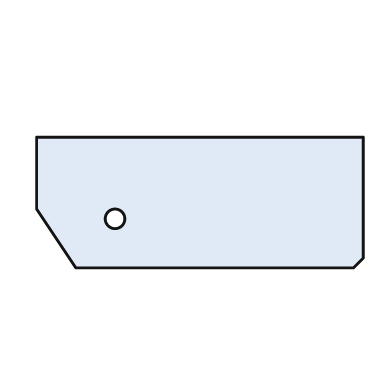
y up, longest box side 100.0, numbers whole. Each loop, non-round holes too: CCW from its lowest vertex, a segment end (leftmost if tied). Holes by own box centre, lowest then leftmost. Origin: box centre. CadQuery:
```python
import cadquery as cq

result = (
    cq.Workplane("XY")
    .moveTo(-38.0, -20.0)
    .lineTo(47.0, -20.0)
    .lineTo(50.0, -17.0)
    .lineTo(50.0, 20.0)
    .lineTo(-50.0, 20.0)
    .lineTo(-50.0, -2.0)
    .close()
    .moveTo(-26.0, -5.0)
    .circle(3.0)
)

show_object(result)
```